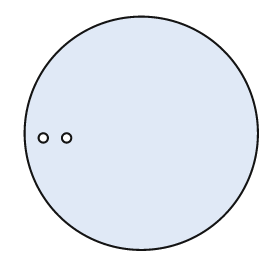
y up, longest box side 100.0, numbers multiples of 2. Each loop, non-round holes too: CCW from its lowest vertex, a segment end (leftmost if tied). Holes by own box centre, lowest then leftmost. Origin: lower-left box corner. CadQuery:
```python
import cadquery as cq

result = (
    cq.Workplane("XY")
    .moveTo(50.0, 50.0)
    .circle(50.0)
    .moveTo(8.0, 48.0)
    .circle(2.0)
    .moveTo(18.0, 48.0)
    .circle(2.0)
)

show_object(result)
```